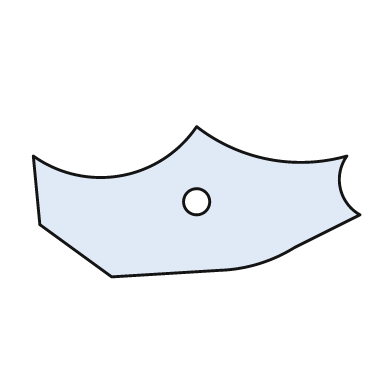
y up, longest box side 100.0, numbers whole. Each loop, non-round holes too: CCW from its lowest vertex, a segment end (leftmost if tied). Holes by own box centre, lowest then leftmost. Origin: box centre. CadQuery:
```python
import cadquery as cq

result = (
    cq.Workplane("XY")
    .moveTo(-26.0, -23.0)
    .lineTo(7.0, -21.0)
    .threePointArc((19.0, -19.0), (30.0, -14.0))
    .lineTo(50.0, -4.0)
    .threePointArc((44.0, 4.0), (46.0, 14.0))
    .threePointArc((22.0, 13.0), (0.0, 23.0))
    .threePointArc((-23.0, 8.0), (-50.0, 14.0))
    .lineTo(-48.0, -7.0)
    .close()
    .moveTo(0.0, 0.0)
    .circle(4.0)
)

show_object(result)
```